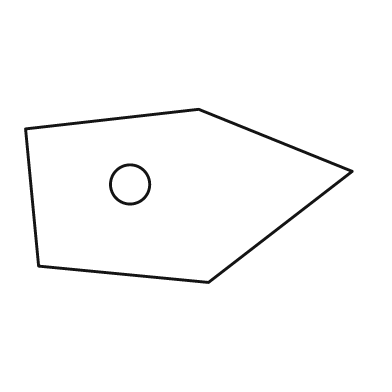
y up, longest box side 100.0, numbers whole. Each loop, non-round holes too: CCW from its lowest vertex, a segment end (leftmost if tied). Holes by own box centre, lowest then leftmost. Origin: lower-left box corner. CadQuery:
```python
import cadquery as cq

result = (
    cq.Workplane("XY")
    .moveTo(56.0, 0.0)
    .lineTo(100.0, 34.0)
    .lineTo(53.0, 53.0)
    .lineTo(0.0, 47.0)
    .lineTo(4.0, 5.0)
    .close()
    .moveTo(32.0, 30.0)
    .circle(6.0)
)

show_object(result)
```